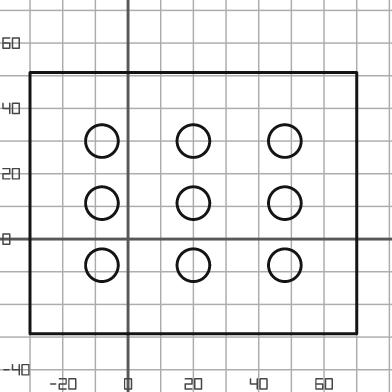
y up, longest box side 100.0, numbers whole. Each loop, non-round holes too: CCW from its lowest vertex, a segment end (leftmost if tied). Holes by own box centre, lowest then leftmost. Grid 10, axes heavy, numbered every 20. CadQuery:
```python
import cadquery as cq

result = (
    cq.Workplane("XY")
    .moveTo(-30.0, -29.0)
    .lineTo(70.0, -29.0)
    .lineTo(70.0, 51.0)
    .lineTo(-30.0, 51.0)
    .close()
    .moveTo(-8.0, -8.0)
    .circle(5.0)
    .moveTo(20.0, -8.0)
    .circle(5.0)
    .moveTo(48.0, -8.0)
    .circle(5.0)
    .moveTo(-8.0, 11.0)
    .circle(5.0)
    .moveTo(20.0, 11.0)
    .circle(5.0)
    .moveTo(48.0, 11.0)
    .circle(5.0)
    .moveTo(-8.0, 30.0)
    .circle(5.0)
    .moveTo(20.0, 30.0)
    .circle(5.0)
    .moveTo(48.0, 30.0)
    .circle(5.0)
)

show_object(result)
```